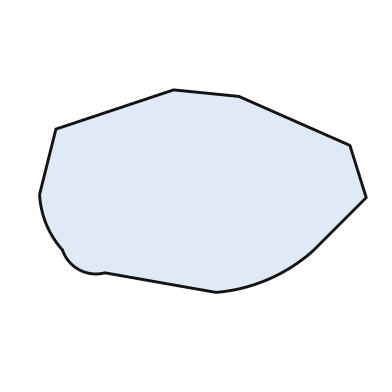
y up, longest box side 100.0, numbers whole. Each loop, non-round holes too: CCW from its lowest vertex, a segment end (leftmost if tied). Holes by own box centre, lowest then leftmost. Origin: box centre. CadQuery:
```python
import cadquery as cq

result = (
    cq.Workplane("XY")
    .moveTo(4.0, -31.0)
    .threePointArc((20.0, -27.0), (34.0, -18.0))
    .lineTo(50.0, -2.0)
    .lineTo(45.0, 14.0)
    .lineTo(11.0, 29.0)
    .lineTo(-9.0, 31.0)
    .lineTo(-45.0, 19.0)
    .lineTo(-50.0, -1.0)
    .threePointArc((-48.0, -10.0), (-43.0, -18.0))
    .threePointArc((-38.0, -24.0), (-30.0, -25.0))
    .close()
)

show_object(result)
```